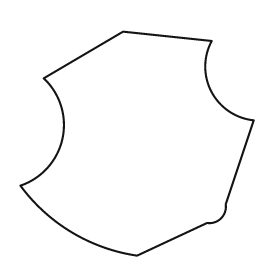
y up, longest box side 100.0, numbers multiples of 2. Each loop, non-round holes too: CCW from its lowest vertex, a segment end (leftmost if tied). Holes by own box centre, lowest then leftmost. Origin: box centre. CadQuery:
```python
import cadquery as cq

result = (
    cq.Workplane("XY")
    .moveTo(0.0, -48.0)
    .lineTo(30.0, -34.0)
    .threePointArc((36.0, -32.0), (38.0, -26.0))
    .lineTo(50.0, 10.0)
    .threePointArc((32.0, 22.0), (32.0, 44.0))
    .lineTo(-6.0, 48.0)
    .lineTo(-40.0, 28.0)
    .threePointArc((-32.0, 2.0), (-50.0, -18.0))
    .threePointArc((-28.0, -38.0), (0.0, -48.0))
    .close()
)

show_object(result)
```